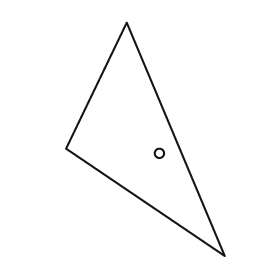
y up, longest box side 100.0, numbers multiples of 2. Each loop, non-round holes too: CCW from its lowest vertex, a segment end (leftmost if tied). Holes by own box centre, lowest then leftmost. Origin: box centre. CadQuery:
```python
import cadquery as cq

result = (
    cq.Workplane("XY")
    .moveTo(34.0, -50.0)
    .lineTo(-8.0, 50.0)
    .lineTo(-34.0, -4.0)
    .close()
    .moveTo(6.0, -6.0)
    .circle(2.0)
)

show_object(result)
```